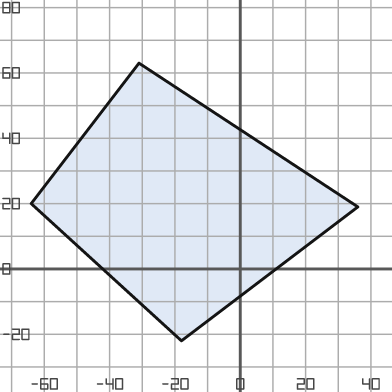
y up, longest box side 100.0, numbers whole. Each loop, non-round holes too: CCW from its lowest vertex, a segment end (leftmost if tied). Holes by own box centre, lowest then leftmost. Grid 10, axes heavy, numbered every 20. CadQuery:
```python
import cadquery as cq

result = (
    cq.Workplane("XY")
    .moveTo(-18.0, -22.0)
    .lineTo(36.0, 19.0)
    .lineTo(-31.0, 63.0)
    .lineTo(-64.0, 20.0)
    .close()
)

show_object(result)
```